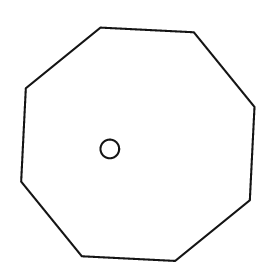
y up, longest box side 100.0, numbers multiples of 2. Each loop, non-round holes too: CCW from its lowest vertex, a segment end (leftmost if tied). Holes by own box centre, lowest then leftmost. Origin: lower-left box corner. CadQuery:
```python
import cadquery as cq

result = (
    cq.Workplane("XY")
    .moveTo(66.0, 0.0)
    .lineTo(98.0, 26.0)
    .lineTo(100.0, 66.0)
    .lineTo(74.0, 98.0)
    .lineTo(34.0, 100.0)
    .lineTo(2.0, 74.0)
    .lineTo(0.0, 34.0)
    .lineTo(26.0, 2.0)
    .close()
    .moveTo(38.0, 48.0)
    .circle(4.0)
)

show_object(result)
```